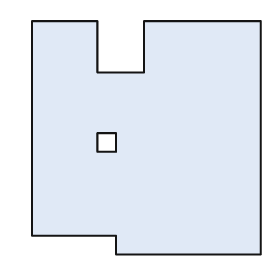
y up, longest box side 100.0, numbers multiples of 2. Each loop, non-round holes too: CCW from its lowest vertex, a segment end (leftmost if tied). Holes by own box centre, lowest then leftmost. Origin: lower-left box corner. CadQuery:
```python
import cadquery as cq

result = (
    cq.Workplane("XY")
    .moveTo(36.0, 0.0)
    .lineTo(98.0, 0.0)
    .lineTo(98.0, 100.0)
    .lineTo(48.0, 100.0)
    .lineTo(48.0, 78.0)
    .lineTo(28.0, 78.0)
    .lineTo(28.0, 100.0)
    .lineTo(0.0, 100.0)
    .lineTo(0.0, 8.0)
    .lineTo(36.0, 8.0)
    .close()
    .moveTo(28.0, 44.0)
    .lineTo(36.0, 44.0)
    .lineTo(36.0, 52.0)
    .lineTo(28.0, 52.0)
    .close()
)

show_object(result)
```